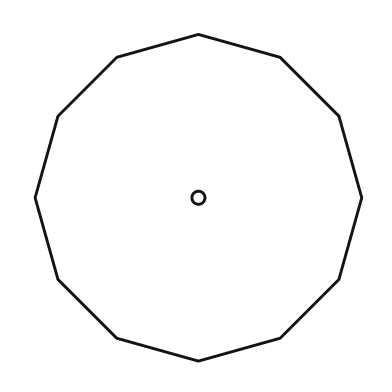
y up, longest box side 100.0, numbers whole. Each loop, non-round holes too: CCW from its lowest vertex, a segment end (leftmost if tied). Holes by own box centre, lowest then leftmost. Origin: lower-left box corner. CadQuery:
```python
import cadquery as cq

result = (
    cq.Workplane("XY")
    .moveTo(50.0, 0.0)
    .lineTo(75.0, 7.0)
    .lineTo(93.0, 25.0)
    .lineTo(100.0, 50.0)
    .lineTo(93.0, 75.0)
    .lineTo(75.0, 93.0)
    .lineTo(50.0, 100.0)
    .lineTo(25.0, 93.0)
    .lineTo(7.0, 75.0)
    .lineTo(0.0, 50.0)
    .lineTo(7.0, 25.0)
    .lineTo(25.0, 7.0)
    .close()
    .moveTo(50.0, 50.0)
    .circle(2.0)
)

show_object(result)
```